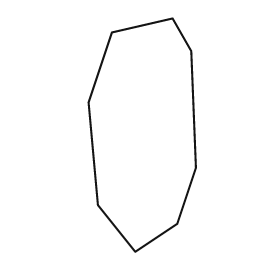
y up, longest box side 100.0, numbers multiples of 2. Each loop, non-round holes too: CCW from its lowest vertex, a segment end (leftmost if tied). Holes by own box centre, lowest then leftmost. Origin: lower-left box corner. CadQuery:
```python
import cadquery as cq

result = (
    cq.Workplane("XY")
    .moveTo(20.0, 0.0)
    .lineTo(38.0, 12.0)
    .lineTo(46.0, 36.0)
    .lineTo(44.0, 86.0)
    .lineTo(36.0, 100.0)
    .lineTo(10.0, 94.0)
    .lineTo(0.0, 64.0)
    .lineTo(4.0, 20.0)
    .close()
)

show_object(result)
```